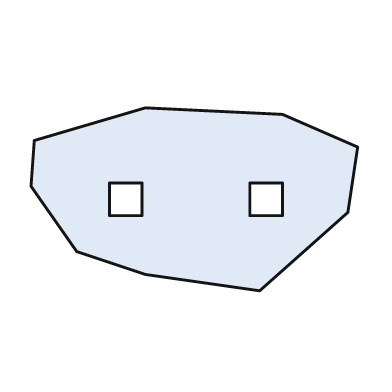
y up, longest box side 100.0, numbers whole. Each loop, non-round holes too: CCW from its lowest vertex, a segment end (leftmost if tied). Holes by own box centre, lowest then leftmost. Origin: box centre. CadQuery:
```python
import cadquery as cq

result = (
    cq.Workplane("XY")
    .moveTo(20.0, -28.0)
    .lineTo(47.0, -4.0)
    .lineTo(50.0, 16.0)
    .lineTo(27.0, 26.0)
    .lineTo(-15.0, 28.0)
    .lineTo(-49.0, 18.0)
    .lineTo(-50.0, 4.0)
    .lineTo(-36.0, -16.0)
    .lineTo(-15.0, -23.0)
    .close()
    .moveTo(-26.0, -5.0)
    .lineTo(-16.0, -5.0)
    .lineTo(-16.0, 5.0)
    .lineTo(-26.0, 5.0)
    .close()
    .moveTo(17.0, -5.0)
    .lineTo(27.0, -5.0)
    .lineTo(27.0, 5.0)
    .lineTo(17.0, 5.0)
    .close()
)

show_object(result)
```